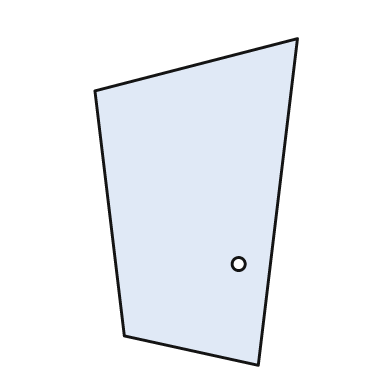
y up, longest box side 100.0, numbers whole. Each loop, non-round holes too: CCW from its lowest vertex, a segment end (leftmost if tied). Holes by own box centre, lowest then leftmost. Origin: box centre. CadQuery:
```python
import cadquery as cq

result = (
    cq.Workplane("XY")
    .moveTo(19.0, -50.0)
    .lineTo(31.0, 50.0)
    .lineTo(-31.0, 34.0)
    .lineTo(-22.0, -41.0)
    .close()
    .moveTo(13.0, -19.0)
    .circle(2.0)
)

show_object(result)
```